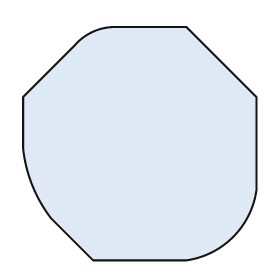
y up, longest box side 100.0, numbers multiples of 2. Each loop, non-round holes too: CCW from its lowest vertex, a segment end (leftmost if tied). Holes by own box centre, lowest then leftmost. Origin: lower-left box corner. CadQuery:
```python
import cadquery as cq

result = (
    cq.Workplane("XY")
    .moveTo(30.0, 0.0)
    .lineTo(70.0, 0.0)
    .threePointArc((90.0, 10.0), (100.0, 30.0))
    .lineTo(100.0, 70.0)
    .lineTo(70.0, 100.0)
    .lineTo(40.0, 100.0)
    .threePointArc((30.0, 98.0), (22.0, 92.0))
    .lineTo(0.0, 70.0)
    .lineTo(0.0, 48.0)
    .threePointArc((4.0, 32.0), (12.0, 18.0))
    .close()
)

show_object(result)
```